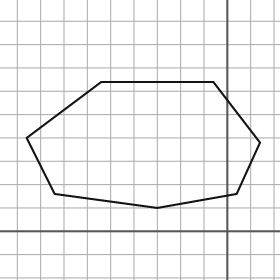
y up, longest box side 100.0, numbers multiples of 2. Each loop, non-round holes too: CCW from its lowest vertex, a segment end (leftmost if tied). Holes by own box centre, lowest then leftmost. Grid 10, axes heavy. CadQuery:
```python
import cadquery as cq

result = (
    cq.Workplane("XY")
    .moveTo(-30.0, 10.0)
    .lineTo(4.0, 16.0)
    .lineTo(14.0, 38.0)
    .lineTo(-6.0, 64.0)
    .lineTo(-54.0, 64.0)
    .lineTo(-86.0, 40.0)
    .lineTo(-74.0, 16.0)
    .close()
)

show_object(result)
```